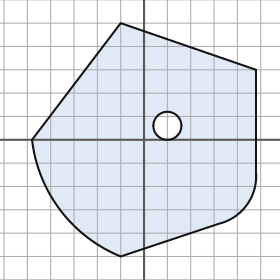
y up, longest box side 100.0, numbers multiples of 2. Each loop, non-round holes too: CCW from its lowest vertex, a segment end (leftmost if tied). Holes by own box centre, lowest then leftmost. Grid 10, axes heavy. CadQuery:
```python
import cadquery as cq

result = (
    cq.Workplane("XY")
    .moveTo(-10.0, -50.0)
    .lineTo(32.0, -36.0)
    .threePointArc((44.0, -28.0), (48.0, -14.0))
    .lineTo(48.0, 30.0)
    .lineTo(-10.0, 50.0)
    .lineTo(-48.0, 0.0)
    .threePointArc((-36.0, -30.0), (-10.0, -50.0))
    .close()
    .moveTo(10.0, 6.0)
    .circle(6.0)
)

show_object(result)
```